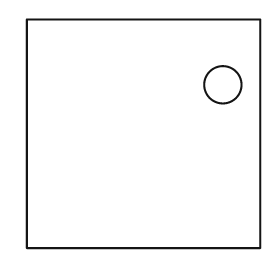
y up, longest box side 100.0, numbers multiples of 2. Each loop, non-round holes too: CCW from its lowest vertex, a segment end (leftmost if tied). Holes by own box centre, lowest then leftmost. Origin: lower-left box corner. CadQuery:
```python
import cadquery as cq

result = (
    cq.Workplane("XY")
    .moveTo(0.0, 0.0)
    .lineTo(100.0, 0.0)
    .lineTo(100.0, 98.0)
    .lineTo(0.0, 98.0)
    .close()
    .moveTo(84.0, 70.0)
    .circle(8.0)
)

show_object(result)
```